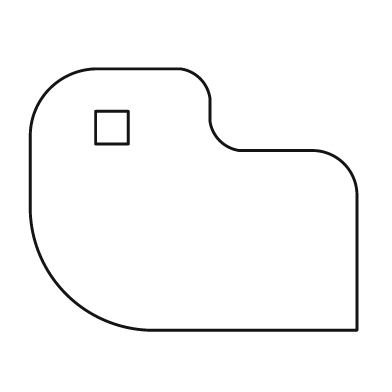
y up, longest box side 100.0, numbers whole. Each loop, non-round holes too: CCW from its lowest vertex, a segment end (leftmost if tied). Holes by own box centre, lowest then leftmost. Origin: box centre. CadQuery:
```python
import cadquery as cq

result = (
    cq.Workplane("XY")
    .moveTo(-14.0, -40.0)
    .lineTo(50.0, -40.0)
    .lineTo(50.0, 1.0)
    .threePointArc((46.0, 11.0), (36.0, 15.0))
    .lineTo(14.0, 15.0)
    .threePointArc((8.0, 18.0), (5.0, 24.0))
    .lineTo(5.0, 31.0)
    .threePointArc((2.0, 37.0), (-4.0, 40.0))
    .lineTo(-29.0, 40.0)
    .threePointArc((-44.0, 34.0), (-50.0, 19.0))
    .lineTo(-50.0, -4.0)
    .threePointArc((-39.0, -29.0), (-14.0, -40.0))
    .close()
    .moveTo(-30.0, 17.0)
    .lineTo(-20.0, 17.0)
    .lineTo(-20.0, 27.0)
    .lineTo(-30.0, 27.0)
    .close()
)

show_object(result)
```